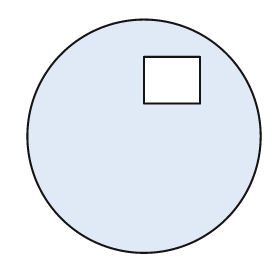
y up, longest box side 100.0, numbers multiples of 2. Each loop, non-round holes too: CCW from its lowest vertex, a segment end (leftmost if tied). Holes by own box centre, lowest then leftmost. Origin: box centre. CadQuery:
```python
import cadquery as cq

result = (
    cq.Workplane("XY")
    .moveTo(0.0, 0.0)
    .circle(50.0)
    .moveTo(0.0, 14.0)
    .lineTo(24.0, 14.0)
    .lineTo(24.0, 34.0)
    .lineTo(0.0, 34.0)
    .close()
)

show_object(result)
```